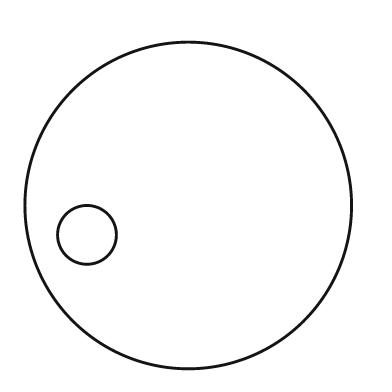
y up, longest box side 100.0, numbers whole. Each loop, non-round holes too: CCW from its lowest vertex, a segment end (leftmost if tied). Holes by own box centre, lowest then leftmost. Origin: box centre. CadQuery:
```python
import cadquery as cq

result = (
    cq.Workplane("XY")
    .moveTo(0.0, 0.0)
    .circle(50.0)
    .moveTo(-31.0, -9.0)
    .circle(9.0)
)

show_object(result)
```